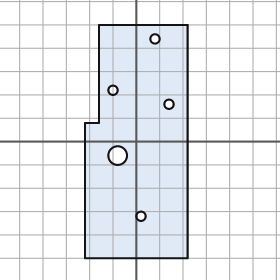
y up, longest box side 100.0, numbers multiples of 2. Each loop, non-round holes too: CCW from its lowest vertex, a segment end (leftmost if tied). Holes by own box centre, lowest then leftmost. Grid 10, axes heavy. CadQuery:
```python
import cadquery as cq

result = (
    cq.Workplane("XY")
    .moveTo(-22.0, -50.0)
    .lineTo(22.0, -50.0)
    .lineTo(22.0, 50.0)
    .lineTo(-16.0, 50.0)
    .lineTo(-16.0, 8.0)
    .lineTo(-22.0, 8.0)
    .close()
    .moveTo(2.0, -32.0)
    .circle(2.0)
    .moveTo(-8.0, -6.0)
    .circle(4.0)
    .moveTo(14.0, 16.0)
    .circle(2.0)
    .moveTo(-10.0, 22.0)
    .circle(2.0)
    .moveTo(8.0, 44.0)
    .circle(2.0)
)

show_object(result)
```